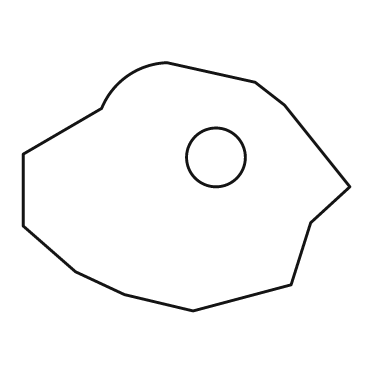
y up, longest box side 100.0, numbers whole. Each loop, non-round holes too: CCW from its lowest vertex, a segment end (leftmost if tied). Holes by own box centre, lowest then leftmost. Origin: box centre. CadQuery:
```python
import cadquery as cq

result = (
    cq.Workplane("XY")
    .moveTo(2.0, -38.0)
    .lineTo(32.0, -30.0)
    .lineTo(38.0, -11.0)
    .lineTo(50.0, 0.0)
    .lineTo(30.0, 25.0)
    .lineTo(21.0, 32.0)
    .lineTo(-6.0, 38.0)
    .threePointArc((-18.0, 34.0), (-26.0, 24.0))
    .lineTo(-50.0, 10.0)
    .lineTo(-50.0, -12.0)
    .lineTo(-34.0, -26.0)
    .lineTo(-19.0, -33.0)
    .close()
    .moveTo(9.0, 9.0)
    .circle(9.0)
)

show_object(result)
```